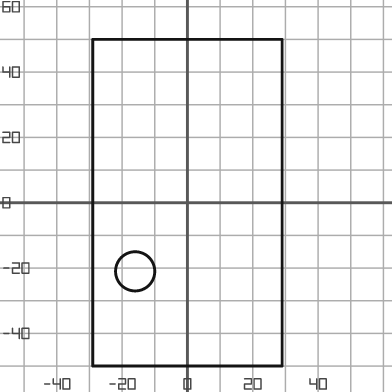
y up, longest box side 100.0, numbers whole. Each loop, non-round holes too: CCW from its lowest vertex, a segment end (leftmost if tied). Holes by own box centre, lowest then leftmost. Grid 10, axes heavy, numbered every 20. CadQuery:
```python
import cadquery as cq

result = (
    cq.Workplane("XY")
    .moveTo(-29.0, -50.0)
    .lineTo(29.0, -50.0)
    .lineTo(29.0, 50.0)
    .lineTo(-29.0, 50.0)
    .close()
    .moveTo(-16.0, -21.0)
    .circle(6.0)
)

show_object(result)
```